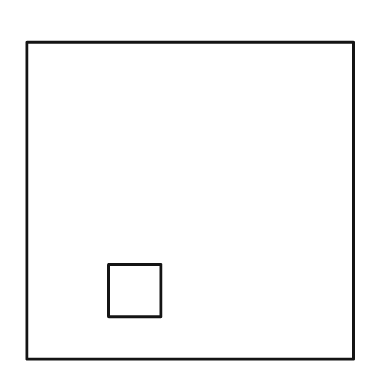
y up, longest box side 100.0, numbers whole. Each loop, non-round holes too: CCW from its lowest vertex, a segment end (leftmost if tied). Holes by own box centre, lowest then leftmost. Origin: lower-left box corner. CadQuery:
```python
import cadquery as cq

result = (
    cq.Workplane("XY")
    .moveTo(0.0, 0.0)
    .lineTo(100.0, 0.0)
    .lineTo(100.0, 97.0)
    .lineTo(0.0, 97.0)
    .close()
    .moveTo(25.0, 13.0)
    .lineTo(41.0, 13.0)
    .lineTo(41.0, 29.0)
    .lineTo(25.0, 29.0)
    .close()
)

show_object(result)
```